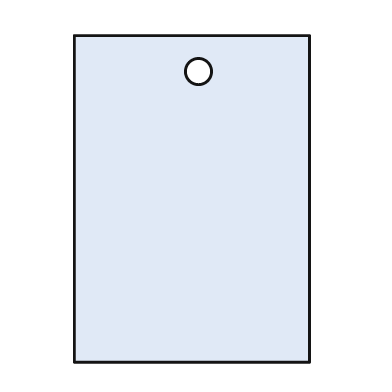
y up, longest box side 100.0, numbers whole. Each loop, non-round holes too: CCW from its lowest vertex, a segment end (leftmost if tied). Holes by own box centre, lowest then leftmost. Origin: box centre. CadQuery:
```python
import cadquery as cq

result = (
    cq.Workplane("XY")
    .moveTo(-36.0, -50.0)
    .lineTo(36.0, -50.0)
    .lineTo(36.0, 50.0)
    .lineTo(-36.0, 50.0)
    .close()
    .moveTo(2.0, 39.0)
    .circle(4.0)
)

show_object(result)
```